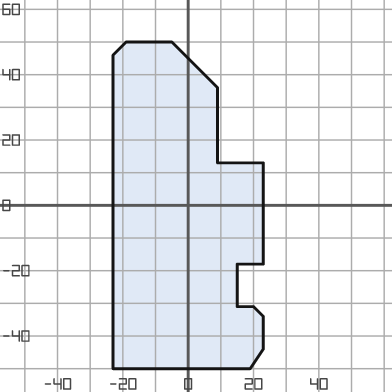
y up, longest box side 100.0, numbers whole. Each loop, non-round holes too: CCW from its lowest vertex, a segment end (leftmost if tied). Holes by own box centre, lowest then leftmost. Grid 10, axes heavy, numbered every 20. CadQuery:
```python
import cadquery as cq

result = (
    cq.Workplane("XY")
    .moveTo(-23.0, -50.0)
    .lineTo(19.0, -50.0)
    .lineTo(23.0, -44.0)
    .lineTo(23.0, -34.0)
    .lineTo(20.0, -31.0)
    .lineTo(15.0, -31.0)
    .lineTo(15.0, -18.0)
    .lineTo(23.0, -18.0)
    .lineTo(23.0, 13.0)
    .lineTo(9.0, 13.0)
    .lineTo(9.0, 36.0)
    .lineTo(-5.0, 50.0)
    .lineTo(-19.0, 50.0)
    .lineTo(-23.0, 46.0)
    .close()
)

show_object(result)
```